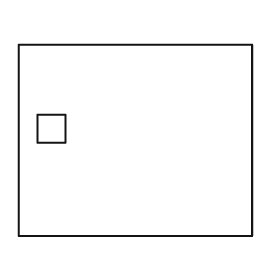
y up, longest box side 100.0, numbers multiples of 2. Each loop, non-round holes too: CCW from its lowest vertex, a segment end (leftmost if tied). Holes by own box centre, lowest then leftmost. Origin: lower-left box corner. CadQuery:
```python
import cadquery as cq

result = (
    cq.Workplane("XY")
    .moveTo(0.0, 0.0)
    .lineTo(100.0, 0.0)
    .lineTo(100.0, 82.0)
    .lineTo(0.0, 82.0)
    .close()
    .moveTo(8.0, 40.0)
    .lineTo(20.0, 40.0)
    .lineTo(20.0, 52.0)
    .lineTo(8.0, 52.0)
    .close()
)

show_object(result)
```